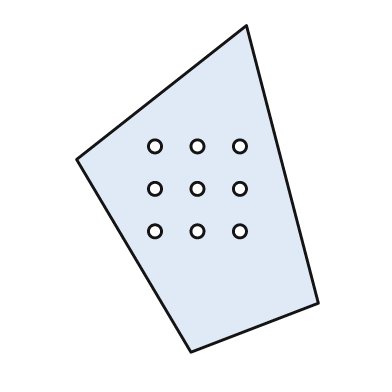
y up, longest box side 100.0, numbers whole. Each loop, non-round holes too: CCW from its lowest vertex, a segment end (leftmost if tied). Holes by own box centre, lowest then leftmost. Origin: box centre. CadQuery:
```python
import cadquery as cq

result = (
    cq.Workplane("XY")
    .moveTo(-2.0, -50.0)
    .lineTo(37.0, -35.0)
    .lineTo(15.0, 50.0)
    .lineTo(-37.0, 9.0)
    .close()
    .moveTo(-13.0, -13.0)
    .circle(2.0)
    .moveTo(0.0, -13.0)
    .circle(2.0)
    .moveTo(13.0, -13.0)
    .circle(2.0)
    .moveTo(-13.0, 0.0)
    .circle(2.0)
    .moveTo(0.0, 0.0)
    .circle(2.0)
    .moveTo(13.0, 0.0)
    .circle(2.0)
    .moveTo(-13.0, 13.0)
    .circle(2.0)
    .moveTo(0.0, 13.0)
    .circle(2.0)
    .moveTo(13.0, 13.0)
    .circle(2.0)
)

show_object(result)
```